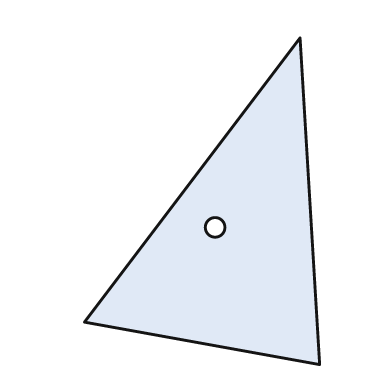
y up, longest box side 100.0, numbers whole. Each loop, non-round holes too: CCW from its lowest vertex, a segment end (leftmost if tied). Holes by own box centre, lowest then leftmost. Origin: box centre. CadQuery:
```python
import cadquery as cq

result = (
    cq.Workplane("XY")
    .moveTo(36.0, -50.0)
    .lineTo(30.0, 50.0)
    .lineTo(-36.0, -37.0)
    .close()
    .moveTo(4.0, -8.0)
    .circle(3.0)
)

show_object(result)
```